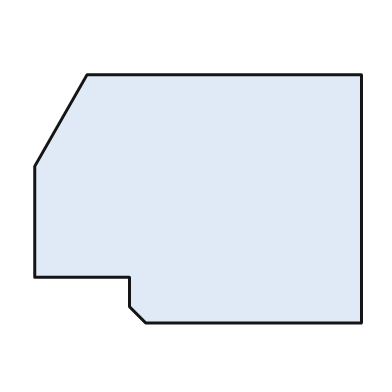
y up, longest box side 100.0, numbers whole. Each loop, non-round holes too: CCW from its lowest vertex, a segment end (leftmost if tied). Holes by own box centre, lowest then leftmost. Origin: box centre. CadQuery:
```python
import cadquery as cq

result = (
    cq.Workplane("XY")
    .moveTo(-16.0, -38.0)
    .lineTo(50.0, -38.0)
    .lineTo(50.0, 38.0)
    .lineTo(-34.0, 38.0)
    .lineTo(-50.0, 10.0)
    .lineTo(-50.0, -24.0)
    .lineTo(-21.0, -24.0)
    .lineTo(-21.0, -33.0)
    .close()
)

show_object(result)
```